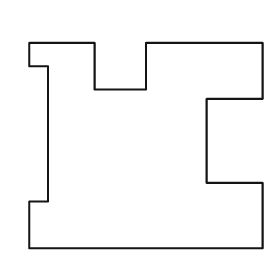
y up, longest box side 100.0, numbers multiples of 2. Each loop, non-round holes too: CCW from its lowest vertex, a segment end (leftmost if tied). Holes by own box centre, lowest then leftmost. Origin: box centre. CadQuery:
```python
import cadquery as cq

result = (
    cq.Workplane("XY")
    .moveTo(-50.0, -44.0)
    .lineTo(50.0, -44.0)
    .lineTo(50.0, -16.0)
    .lineTo(26.0, -16.0)
    .lineTo(26.0, 20.0)
    .lineTo(50.0, 20.0)
    .lineTo(50.0, 44.0)
    .lineTo(0.0, 44.0)
    .lineTo(0.0, 24.0)
    .lineTo(-22.0, 24.0)
    .lineTo(-22.0, 44.0)
    .lineTo(-50.0, 44.0)
    .lineTo(-50.0, 34.0)
    .lineTo(-42.0, 34.0)
    .lineTo(-42.0, -24.0)
    .lineTo(-50.0, -24.0)
    .close()
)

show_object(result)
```